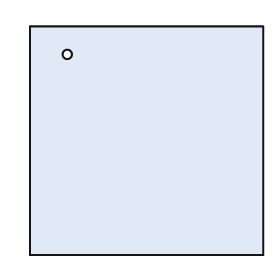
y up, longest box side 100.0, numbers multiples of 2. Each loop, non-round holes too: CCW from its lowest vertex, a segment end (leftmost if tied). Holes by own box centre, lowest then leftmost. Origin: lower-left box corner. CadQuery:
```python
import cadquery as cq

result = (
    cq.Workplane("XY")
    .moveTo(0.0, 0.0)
    .lineTo(100.0, 0.0)
    .lineTo(100.0, 98.0)
    .lineTo(0.0, 98.0)
    .close()
    .moveTo(16.0, 86.0)
    .circle(2.0)
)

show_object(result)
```